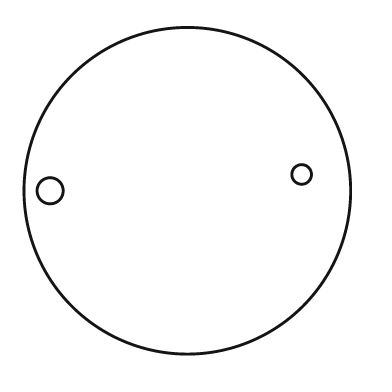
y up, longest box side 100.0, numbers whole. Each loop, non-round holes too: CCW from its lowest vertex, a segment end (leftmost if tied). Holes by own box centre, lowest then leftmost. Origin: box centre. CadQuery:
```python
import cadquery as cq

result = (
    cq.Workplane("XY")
    .moveTo(0.0, 0.0)
    .circle(50.0)
    .moveTo(-42.0, 0.0)
    .circle(4.0)
    .moveTo(35.0, 5.0)
    .circle(3.0)
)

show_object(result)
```